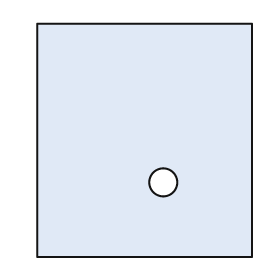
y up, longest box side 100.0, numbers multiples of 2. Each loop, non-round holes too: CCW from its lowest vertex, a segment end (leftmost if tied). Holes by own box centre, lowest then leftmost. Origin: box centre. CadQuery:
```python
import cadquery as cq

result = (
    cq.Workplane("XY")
    .moveTo(-46.0, -50.0)
    .lineTo(46.0, -50.0)
    .lineTo(46.0, 50.0)
    .lineTo(-46.0, 50.0)
    .close()
    .moveTo(8.0, -18.0)
    .circle(6.0)
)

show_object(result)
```